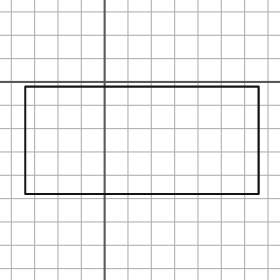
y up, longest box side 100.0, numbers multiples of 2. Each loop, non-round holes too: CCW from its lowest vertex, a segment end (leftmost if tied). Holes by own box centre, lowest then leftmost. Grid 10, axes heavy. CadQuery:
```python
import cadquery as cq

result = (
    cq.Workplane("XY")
    .moveTo(-34.0, -48.0)
    .lineTo(66.0, -48.0)
    .lineTo(66.0, -2.0)
    .lineTo(-34.0, -2.0)
    .close()
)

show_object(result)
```